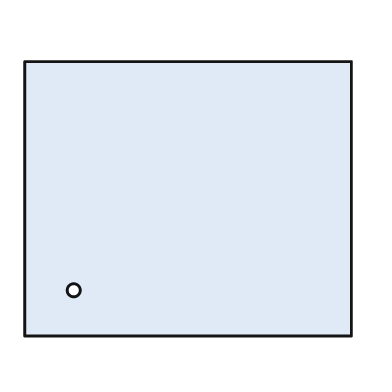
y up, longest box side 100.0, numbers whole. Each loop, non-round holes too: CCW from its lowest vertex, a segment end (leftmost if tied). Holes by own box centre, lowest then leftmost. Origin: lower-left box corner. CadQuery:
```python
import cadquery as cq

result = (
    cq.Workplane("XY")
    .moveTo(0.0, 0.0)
    .lineTo(100.0, 0.0)
    .lineTo(100.0, 84.0)
    .lineTo(0.0, 84.0)
    .close()
    .moveTo(15.0, 14.0)
    .circle(2.0)
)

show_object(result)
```